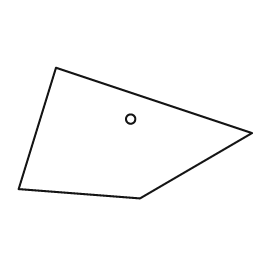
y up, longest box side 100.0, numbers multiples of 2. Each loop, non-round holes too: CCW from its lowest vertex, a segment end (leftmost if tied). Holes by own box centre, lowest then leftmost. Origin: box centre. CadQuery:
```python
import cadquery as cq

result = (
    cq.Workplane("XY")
    .moveTo(2.0, -28.0)
    .lineTo(50.0, 0.0)
    .lineTo(-34.0, 28.0)
    .lineTo(-50.0, -24.0)
    .close()
    .moveTo(-2.0, 6.0)
    .circle(2.0)
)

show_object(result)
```